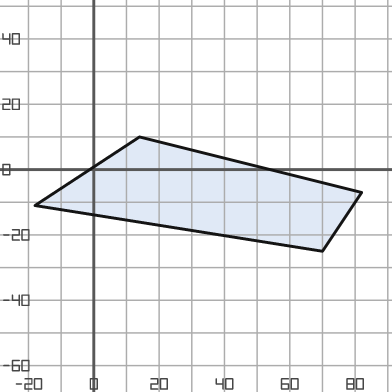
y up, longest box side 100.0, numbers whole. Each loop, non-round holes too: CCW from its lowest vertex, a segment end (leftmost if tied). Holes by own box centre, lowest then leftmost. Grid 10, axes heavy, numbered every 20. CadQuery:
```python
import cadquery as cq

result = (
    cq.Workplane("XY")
    .moveTo(70.0, -25.0)
    .lineTo(82.0, -7.0)
    .lineTo(14.0, 10.0)
    .lineTo(-18.0, -11.0)
    .close()
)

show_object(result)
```